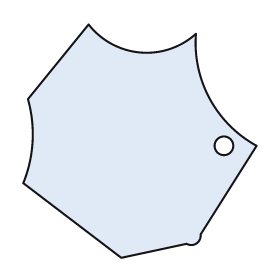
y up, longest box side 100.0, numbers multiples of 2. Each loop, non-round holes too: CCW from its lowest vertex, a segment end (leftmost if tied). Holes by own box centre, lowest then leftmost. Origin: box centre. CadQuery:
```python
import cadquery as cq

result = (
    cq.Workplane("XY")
    .moveTo(-8.0, -50.0)
    .lineTo(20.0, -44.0)
    .threePointArc((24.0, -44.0), (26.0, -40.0))
    .lineTo(50.0, -2.0)
    .threePointArc((30.0, 18.0), (24.0, 46.0))
    .threePointArc((0.0, 38.0), (-22.0, 50.0))
    .lineTo(-48.0, 18.0)
    .threePointArc((-46.0, 0.0), (-50.0, -18.0))
    .close()
    .moveTo(36.0, -2.0)
    .circle(4.0)
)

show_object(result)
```